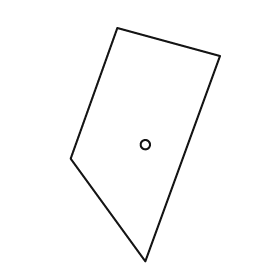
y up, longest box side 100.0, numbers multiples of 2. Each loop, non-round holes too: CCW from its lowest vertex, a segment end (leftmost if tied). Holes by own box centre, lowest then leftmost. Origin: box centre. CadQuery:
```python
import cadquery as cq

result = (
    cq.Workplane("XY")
    .moveTo(0.0, -50.0)
    .lineTo(32.0, 38.0)
    .lineTo(-12.0, 50.0)
    .lineTo(-32.0, -6.0)
    .close()
    .moveTo(0.0, 0.0)
    .circle(2.0)
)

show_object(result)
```